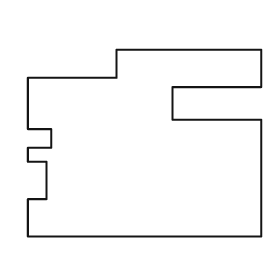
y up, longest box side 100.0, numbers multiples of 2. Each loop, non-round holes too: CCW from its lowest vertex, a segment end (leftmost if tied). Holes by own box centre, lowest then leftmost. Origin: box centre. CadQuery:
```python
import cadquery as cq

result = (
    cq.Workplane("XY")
    .moveTo(-50.0, -40.0)
    .lineTo(50.0, -40.0)
    .lineTo(50.0, 10.0)
    .lineTo(12.0, 10.0)
    .lineTo(12.0, 24.0)
    .lineTo(50.0, 24.0)
    .lineTo(50.0, 40.0)
    .lineTo(-12.0, 40.0)
    .lineTo(-12.0, 28.0)
    .lineTo(-50.0, 28.0)
    .lineTo(-50.0, 6.0)
    .lineTo(-40.0, 6.0)
    .lineTo(-40.0, -2.0)
    .lineTo(-50.0, -2.0)
    .lineTo(-50.0, -8.0)
    .lineTo(-42.0, -8.0)
    .lineTo(-42.0, -24.0)
    .lineTo(-50.0, -24.0)
    .close()
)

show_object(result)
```